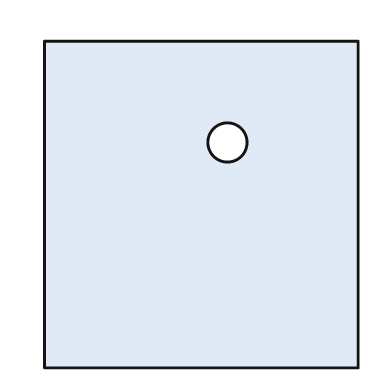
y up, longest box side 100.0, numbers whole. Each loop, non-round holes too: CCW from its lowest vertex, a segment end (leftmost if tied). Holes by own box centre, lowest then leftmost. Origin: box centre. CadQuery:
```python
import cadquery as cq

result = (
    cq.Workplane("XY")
    .moveTo(-48.0, -50.0)
    .lineTo(48.0, -50.0)
    .lineTo(48.0, 50.0)
    .lineTo(-48.0, 50.0)
    .close()
    .moveTo(8.0, 19.0)
    .circle(6.0)
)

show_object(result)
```